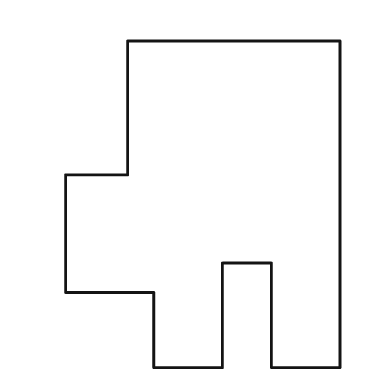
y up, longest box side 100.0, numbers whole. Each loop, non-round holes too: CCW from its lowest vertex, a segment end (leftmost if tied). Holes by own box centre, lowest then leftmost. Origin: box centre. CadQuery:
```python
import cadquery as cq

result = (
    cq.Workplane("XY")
    .moveTo(-15.0, -50.0)
    .lineTo(6.0, -50.0)
    .lineTo(6.0, -18.0)
    .lineTo(21.0, -18.0)
    .lineTo(21.0, -50.0)
    .lineTo(42.0, -50.0)
    .lineTo(42.0, 50.0)
    .lineTo(-23.0, 50.0)
    .lineTo(-23.0, 9.0)
    .lineTo(-42.0, 9.0)
    .lineTo(-42.0, -27.0)
    .lineTo(-15.0, -27.0)
    .close()
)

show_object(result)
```